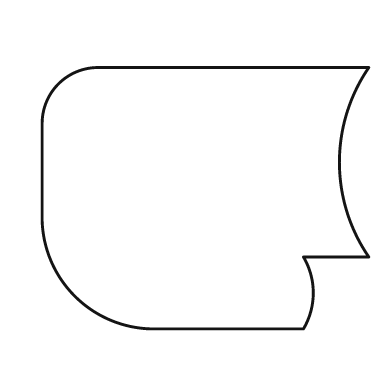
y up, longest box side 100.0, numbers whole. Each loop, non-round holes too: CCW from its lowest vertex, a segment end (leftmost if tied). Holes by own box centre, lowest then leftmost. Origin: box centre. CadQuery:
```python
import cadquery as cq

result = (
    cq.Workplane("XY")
    .moveTo(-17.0, -40.0)
    .lineTo(30.0, -40.0)
    .threePointArc((33.0, -29.0), (30.0, -18.0))
    .lineTo(50.0, -18.0)
    .threePointArc((41.0, 11.0), (50.0, 40.0))
    .lineTo(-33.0, 40.0)
    .threePointArc((-45.0, 35.0), (-50.0, 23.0))
    .lineTo(-50.0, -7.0)
    .threePointArc((-40.0, -30.0), (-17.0, -40.0))
    .close()
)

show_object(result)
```